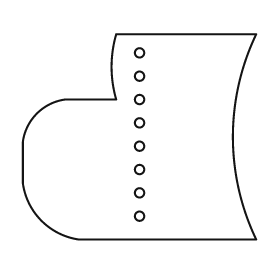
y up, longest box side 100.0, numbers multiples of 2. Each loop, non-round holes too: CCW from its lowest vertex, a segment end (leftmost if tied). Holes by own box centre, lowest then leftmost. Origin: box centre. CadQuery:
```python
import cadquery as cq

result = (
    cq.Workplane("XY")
    .moveTo(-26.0, -44.0)
    .lineTo(50.0, -44.0)
    .threePointArc((40.0, 0.0), (50.0, 44.0))
    .lineTo(-10.0, 44.0)
    .threePointArc((-12.0, 30.0), (-10.0, 16.0))
    .lineTo(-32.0, 16.0)
    .threePointArc((-44.0, 10.0), (-50.0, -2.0))
    .lineTo(-50.0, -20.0)
    .threePointArc((-42.0, -36.0), (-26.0, -44.0))
    .close()
    .moveTo(0.0, -34.0)
    .circle(2.0)
    .moveTo(0.0, -24.0)
    .circle(2.0)
    .moveTo(0.0, -14.0)
    .circle(2.0)
    .moveTo(0.0, -4.0)
    .circle(2.0)
    .moveTo(0.0, 6.0)
    .circle(2.0)
    .moveTo(0.0, 16.0)
    .circle(2.0)
    .moveTo(0.0, 26.0)
    .circle(2.0)
    .moveTo(0.0, 36.0)
    .circle(2.0)
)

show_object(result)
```